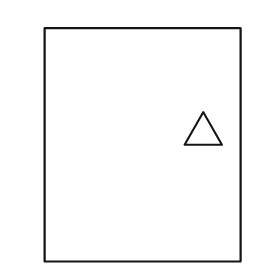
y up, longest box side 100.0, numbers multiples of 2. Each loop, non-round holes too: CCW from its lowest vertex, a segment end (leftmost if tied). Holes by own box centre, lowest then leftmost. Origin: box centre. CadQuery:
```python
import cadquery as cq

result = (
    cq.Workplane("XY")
    .moveTo(-42.0, -50.0)
    .lineTo(42.0, -50.0)
    .lineTo(42.0, 50.0)
    .lineTo(-42.0, 50.0)
    .close()
    .moveTo(18.0, 0.0)
    .lineTo(34.0, 0.0)
    .lineTo(26.0, 14.0)
    .close()
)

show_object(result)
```